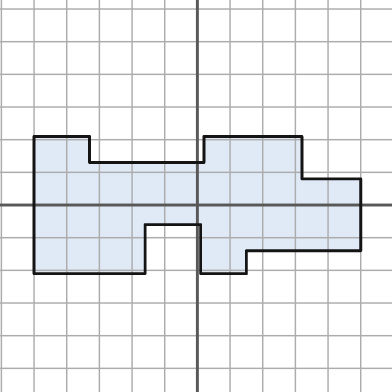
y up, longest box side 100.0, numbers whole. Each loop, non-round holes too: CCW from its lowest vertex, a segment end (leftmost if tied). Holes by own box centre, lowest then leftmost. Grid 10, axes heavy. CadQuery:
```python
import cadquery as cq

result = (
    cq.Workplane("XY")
    .moveTo(-50.0, -21.0)
    .lineTo(-16.0, -21.0)
    .lineTo(-16.0, -6.0)
    .lineTo(1.0, -6.0)
    .lineTo(1.0, -21.0)
    .lineTo(15.0, -21.0)
    .lineTo(15.0, -14.0)
    .lineTo(50.0, -14.0)
    .lineTo(50.0, 8.0)
    .lineTo(32.0, 8.0)
    .lineTo(32.0, 21.0)
    .lineTo(2.0, 21.0)
    .lineTo(2.0, 13.0)
    .lineTo(-33.0, 13.0)
    .lineTo(-33.0, 21.0)
    .lineTo(-50.0, 21.0)
    .close()
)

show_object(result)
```